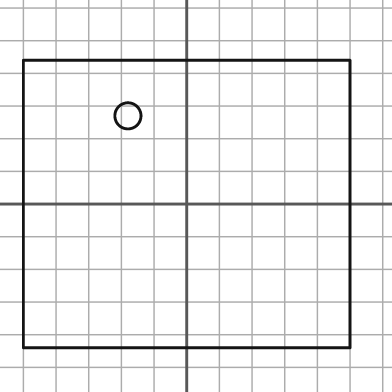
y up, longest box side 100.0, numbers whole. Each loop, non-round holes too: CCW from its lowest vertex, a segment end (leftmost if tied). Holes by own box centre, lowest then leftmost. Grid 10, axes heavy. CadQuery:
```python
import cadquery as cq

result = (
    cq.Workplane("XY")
    .moveTo(-50.0, -44.0)
    .lineTo(50.0, -44.0)
    .lineTo(50.0, 44.0)
    .lineTo(-50.0, 44.0)
    .close()
    .moveTo(-18.0, 27.0)
    .circle(4.0)
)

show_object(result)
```